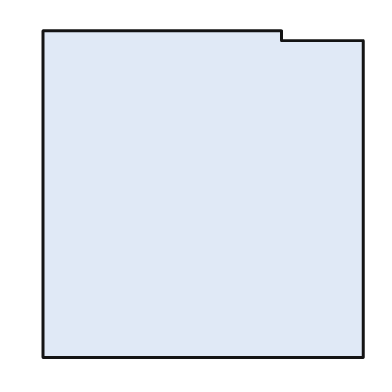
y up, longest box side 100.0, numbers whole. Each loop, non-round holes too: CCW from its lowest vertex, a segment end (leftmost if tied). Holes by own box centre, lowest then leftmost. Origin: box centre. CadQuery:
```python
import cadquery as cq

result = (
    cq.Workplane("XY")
    .moveTo(-49.0, -50.0)
    .lineTo(49.0, -50.0)
    .lineTo(49.0, 47.0)
    .lineTo(24.0, 47.0)
    .lineTo(24.0, 50.0)
    .lineTo(-49.0, 50.0)
    .close()
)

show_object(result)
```